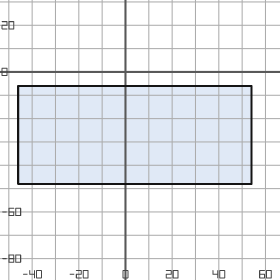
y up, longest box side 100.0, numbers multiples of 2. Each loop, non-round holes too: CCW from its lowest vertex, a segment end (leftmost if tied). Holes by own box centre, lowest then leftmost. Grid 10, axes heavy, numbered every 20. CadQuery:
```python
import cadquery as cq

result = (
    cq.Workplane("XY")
    .moveTo(-46.0, -48.0)
    .lineTo(54.0, -48.0)
    .lineTo(54.0, -6.0)
    .lineTo(-46.0, -6.0)
    .close()
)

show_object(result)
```